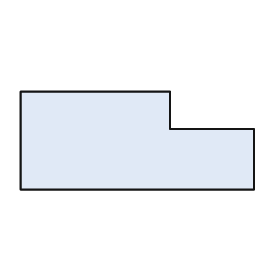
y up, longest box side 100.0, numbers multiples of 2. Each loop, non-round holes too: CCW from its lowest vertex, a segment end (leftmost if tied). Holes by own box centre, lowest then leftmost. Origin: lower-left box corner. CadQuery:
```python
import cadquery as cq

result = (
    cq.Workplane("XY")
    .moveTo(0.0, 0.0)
    .lineTo(100.0, 0.0)
    .lineTo(100.0, 26.0)
    .lineTo(64.0, 26.0)
    .lineTo(64.0, 42.0)
    .lineTo(0.0, 42.0)
    .close()
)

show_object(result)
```